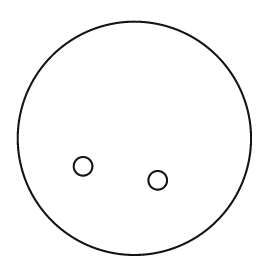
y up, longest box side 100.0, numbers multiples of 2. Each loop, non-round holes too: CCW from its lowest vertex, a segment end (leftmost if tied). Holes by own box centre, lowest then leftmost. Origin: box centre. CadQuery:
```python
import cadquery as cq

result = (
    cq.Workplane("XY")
    .moveTo(0.0, 0.0)
    .circle(50.0)
    .moveTo(10.0, -18.0)
    .circle(4.0)
    .moveTo(-22.0, -12.0)
    .circle(4.0)
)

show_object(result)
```